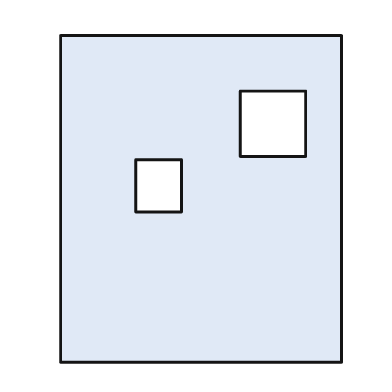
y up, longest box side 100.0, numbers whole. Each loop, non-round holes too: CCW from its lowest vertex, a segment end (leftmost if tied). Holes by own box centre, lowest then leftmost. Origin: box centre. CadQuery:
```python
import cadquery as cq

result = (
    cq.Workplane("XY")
    .moveTo(-43.0, -50.0)
    .lineTo(43.0, -50.0)
    .lineTo(43.0, 50.0)
    .lineTo(-43.0, 50.0)
    .close()
    .moveTo(-20.0, -4.0)
    .lineTo(-6.0, -4.0)
    .lineTo(-6.0, 12.0)
    .lineTo(-20.0, 12.0)
    .close()
    .moveTo(12.0, 13.0)
    .lineTo(32.0, 13.0)
    .lineTo(32.0, 33.0)
    .lineTo(12.0, 33.0)
    .close()
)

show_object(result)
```